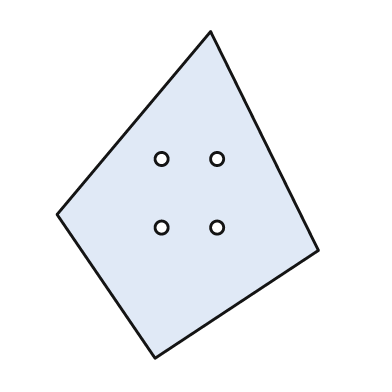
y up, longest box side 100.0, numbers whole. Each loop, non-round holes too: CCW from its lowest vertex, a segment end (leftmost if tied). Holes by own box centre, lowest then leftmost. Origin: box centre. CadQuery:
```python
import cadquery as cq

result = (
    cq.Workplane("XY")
    .moveTo(-10.0, -50.0)
    .lineTo(40.0, -17.0)
    .lineTo(7.0, 50.0)
    .lineTo(-40.0, -6.0)
    .close()
    .moveTo(-8.0, -10.0)
    .circle(2.0)
    .moveTo(9.0, -10.0)
    .circle(2.0)
    .moveTo(-8.0, 11.0)
    .circle(2.0)
    .moveTo(9.0, 11.0)
    .circle(2.0)
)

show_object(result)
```